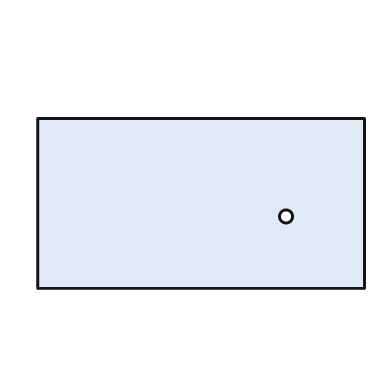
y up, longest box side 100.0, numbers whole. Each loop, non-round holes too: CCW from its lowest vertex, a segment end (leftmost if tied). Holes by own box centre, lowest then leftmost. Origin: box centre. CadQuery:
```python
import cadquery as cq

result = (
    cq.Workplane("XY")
    .moveTo(-50.0, -26.0)
    .lineTo(50.0, -26.0)
    .lineTo(50.0, 26.0)
    .lineTo(-50.0, 26.0)
    .close()
    .moveTo(26.0, -4.0)
    .circle(2.0)
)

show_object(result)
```